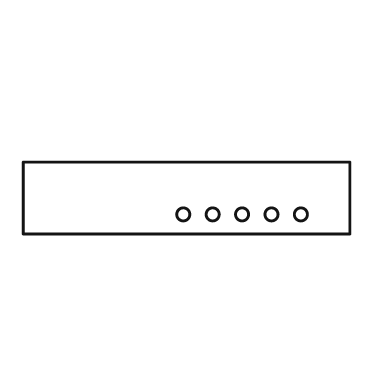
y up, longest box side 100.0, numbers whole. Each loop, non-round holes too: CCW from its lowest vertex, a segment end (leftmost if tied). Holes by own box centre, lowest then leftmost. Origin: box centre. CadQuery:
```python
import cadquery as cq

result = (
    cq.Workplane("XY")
    .moveTo(-50.0, -11.0)
    .lineTo(50.0, -11.0)
    .lineTo(50.0, 11.0)
    .lineTo(-50.0, 11.0)
    .close()
    .moveTo(-1.0, -5.0)
    .circle(2.0)
    .moveTo(8.0, -5.0)
    .circle(2.0)
    .moveTo(17.0, -5.0)
    .circle(2.0)
    .moveTo(26.0, -5.0)
    .circle(2.0)
    .moveTo(35.0, -5.0)
    .circle(2.0)
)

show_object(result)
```